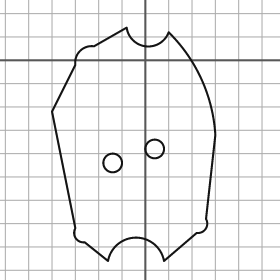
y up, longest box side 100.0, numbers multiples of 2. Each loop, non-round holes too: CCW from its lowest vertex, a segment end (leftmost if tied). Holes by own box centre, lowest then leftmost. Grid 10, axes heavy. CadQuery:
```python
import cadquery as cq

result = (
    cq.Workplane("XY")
    .moveTo(-16.0, -86.0)
    .threePointArc((-4.0, -76.0), (8.0, -86.0))
    .lineTo(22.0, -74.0)
    .threePointArc((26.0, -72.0), (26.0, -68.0))
    .lineTo(30.0, -32.0)
    .threePointArc((24.0, -8.0), (10.0, 12.0))
    .threePointArc((0.0, 6.0), (-8.0, 14.0))
    .lineTo(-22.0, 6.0)
    .threePointArc((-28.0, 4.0), (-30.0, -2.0))
    .lineTo(-40.0, -22.0)
    .lineTo(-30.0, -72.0)
    .threePointArc((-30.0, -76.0), (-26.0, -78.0))
    .close()
    .moveTo(-14.0, -44.0)
    .circle(4.0)
    .moveTo(4.0, -38.0)
    .circle(4.0)
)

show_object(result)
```